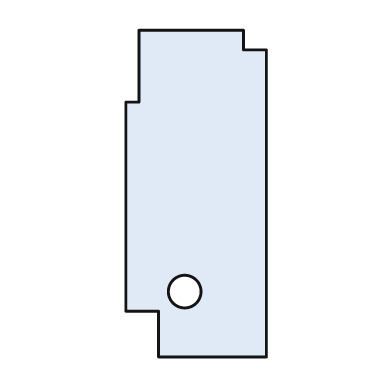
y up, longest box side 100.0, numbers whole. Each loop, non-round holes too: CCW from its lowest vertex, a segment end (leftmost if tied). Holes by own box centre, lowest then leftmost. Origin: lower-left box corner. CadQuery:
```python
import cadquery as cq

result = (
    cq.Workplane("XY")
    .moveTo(10.0, 0.0)
    .lineTo(43.0, 0.0)
    .lineTo(43.0, 94.0)
    .lineTo(36.0, 94.0)
    .lineTo(36.0, 100.0)
    .lineTo(4.0, 100.0)
    .lineTo(4.0, 78.0)
    .lineTo(0.0, 78.0)
    .lineTo(0.0, 14.0)
    .lineTo(10.0, 14.0)
    .close()
    .moveTo(18.0, 20.0)
    .circle(5.0)
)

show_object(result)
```